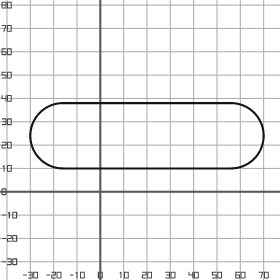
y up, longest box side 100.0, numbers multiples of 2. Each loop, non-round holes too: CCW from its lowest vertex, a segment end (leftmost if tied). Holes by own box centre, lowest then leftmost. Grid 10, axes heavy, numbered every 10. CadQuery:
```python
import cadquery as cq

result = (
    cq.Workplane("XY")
    .moveTo(-16.0, 10.0)
    .lineTo(56.0, 10.0)
    .threePointArc((70.0, 24.0), (56.0, 38.0))
    .lineTo(-16.0, 38.0)
    .threePointArc((-30.0, 24.0), (-16.0, 10.0))
    .close()
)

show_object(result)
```